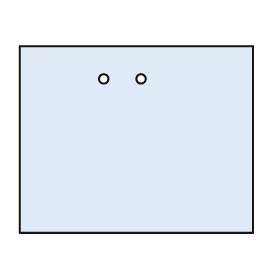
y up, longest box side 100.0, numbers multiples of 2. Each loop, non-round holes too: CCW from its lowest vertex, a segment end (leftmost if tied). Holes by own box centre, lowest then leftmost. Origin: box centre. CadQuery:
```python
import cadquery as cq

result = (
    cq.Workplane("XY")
    .moveTo(-50.0, -40.0)
    .lineTo(50.0, -40.0)
    .lineTo(50.0, 40.0)
    .lineTo(-50.0, 40.0)
    .close()
    .moveTo(-14.0, 26.0)
    .circle(2.0)
    .moveTo(2.0, 26.0)
    .circle(2.0)
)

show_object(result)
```